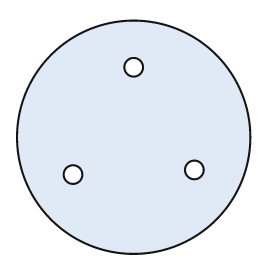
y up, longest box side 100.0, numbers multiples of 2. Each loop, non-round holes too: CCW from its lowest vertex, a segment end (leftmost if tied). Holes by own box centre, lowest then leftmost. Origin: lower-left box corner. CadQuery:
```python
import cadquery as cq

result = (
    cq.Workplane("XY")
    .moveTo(50.0, 50.0)
    .circle(50.0)
    .moveTo(24.0, 34.0)
    .circle(4.0)
    .moveTo(76.0, 36.0)
    .circle(4.0)
    .moveTo(50.0, 80.0)
    .circle(4.0)
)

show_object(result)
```